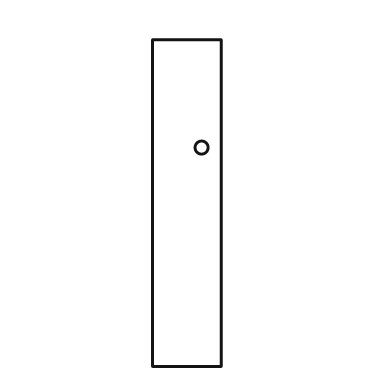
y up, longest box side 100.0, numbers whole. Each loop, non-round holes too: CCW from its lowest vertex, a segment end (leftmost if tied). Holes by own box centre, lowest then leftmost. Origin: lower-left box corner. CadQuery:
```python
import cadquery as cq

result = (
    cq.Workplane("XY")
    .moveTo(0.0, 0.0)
    .lineTo(21.0, 0.0)
    .lineTo(21.0, 100.0)
    .lineTo(0.0, 100.0)
    .close()
    .moveTo(15.0, 67.0)
    .circle(2.0)
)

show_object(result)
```